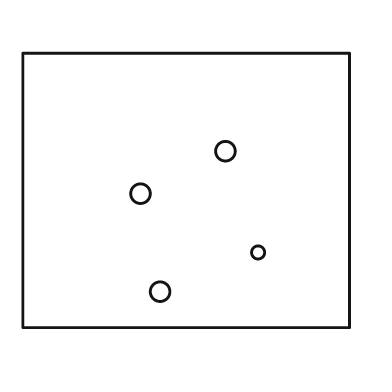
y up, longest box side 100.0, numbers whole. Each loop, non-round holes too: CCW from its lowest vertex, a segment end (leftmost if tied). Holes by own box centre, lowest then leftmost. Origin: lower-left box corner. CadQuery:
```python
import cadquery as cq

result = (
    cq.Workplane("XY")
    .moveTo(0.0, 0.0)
    .lineTo(100.0, 0.0)
    .lineTo(100.0, 84.0)
    .lineTo(0.0, 84.0)
    .close()
    .moveTo(42.0, 11.0)
    .circle(3.0)
    .moveTo(72.0, 23.0)
    .circle(2.0)
    .moveTo(36.0, 41.0)
    .circle(3.0)
    .moveTo(62.0, 54.0)
    .circle(3.0)
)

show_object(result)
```